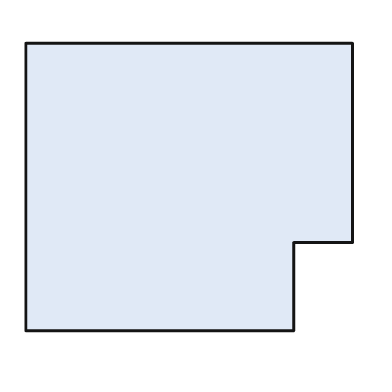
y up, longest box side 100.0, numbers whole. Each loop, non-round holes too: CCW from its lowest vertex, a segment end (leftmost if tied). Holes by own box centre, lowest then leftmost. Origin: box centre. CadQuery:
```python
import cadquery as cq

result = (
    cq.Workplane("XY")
    .moveTo(-50.0, -44.0)
    .lineTo(32.0, -44.0)
    .lineTo(32.0, -17.0)
    .lineTo(50.0, -17.0)
    .lineTo(50.0, 44.0)
    .lineTo(-50.0, 44.0)
    .close()
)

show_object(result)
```